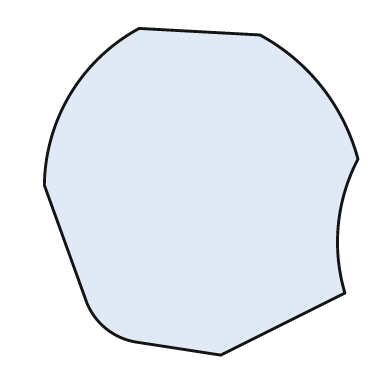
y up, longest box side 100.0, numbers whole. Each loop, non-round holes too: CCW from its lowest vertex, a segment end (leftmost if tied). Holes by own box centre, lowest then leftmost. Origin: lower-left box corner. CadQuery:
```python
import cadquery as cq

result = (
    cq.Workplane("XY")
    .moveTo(54.0, 0.0)
    .lineTo(92.0, 19.0)
    .threePointArc((90.0, 40.0), (96.0, 60.0))
    .threePointArc((85.0, 82.0), (66.0, 98.0))
    .lineTo(29.0, 100.0)
    .threePointArc((8.0, 80.0), (0.0, 52.0))
    .lineTo(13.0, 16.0)
    .threePointArc((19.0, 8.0), (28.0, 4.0))
    .close()
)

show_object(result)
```